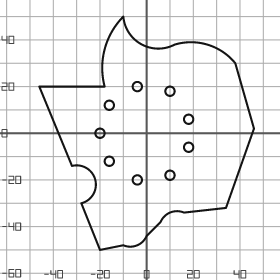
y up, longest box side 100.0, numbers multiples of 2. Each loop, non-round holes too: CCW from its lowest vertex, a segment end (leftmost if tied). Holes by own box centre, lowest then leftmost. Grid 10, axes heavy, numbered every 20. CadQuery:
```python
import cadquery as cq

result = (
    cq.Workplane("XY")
    .moveTo(-20.0, -50.0)
    .lineTo(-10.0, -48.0)
    .threePointArc((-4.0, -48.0), (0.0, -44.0))
    .lineTo(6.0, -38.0)
    .threePointArc((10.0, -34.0), (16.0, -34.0))
    .lineTo(34.0, -32.0)
    .lineTo(46.0, 2.0)
    .lineTo(38.0, 30.0)
    .threePointArc((26.0, 38.0), (12.0, 38.0))
    .threePointArc((-2.0, 38.0), (-10.0, 50.0))
    .threePointArc((-18.0, 36.0), (-18.0, 20.0))
    .lineTo(-46.0, 20.0)
    .lineTo(-32.0, -14.0)
    .threePointArc((-22.0, -20.0), (-28.0, -30.0))
    .close()
    .moveTo(-4.0, -20.0)
    .circle(2.0)
    .moveTo(10.0, -18.0)
    .circle(2.0)
    .moveTo(-16.0, -12.0)
    .circle(2.0)
    .moveTo(18.0, -6.0)
    .circle(2.0)
    .moveTo(-20.0, 0.0)
    .circle(2.0)
    .moveTo(18.0, 6.0)
    .circle(2.0)
    .moveTo(-16.0, 12.0)
    .circle(2.0)
    .moveTo(10.0, 18.0)
    .circle(2.0)
    .moveTo(-4.0, 20.0)
    .circle(2.0)
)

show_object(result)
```